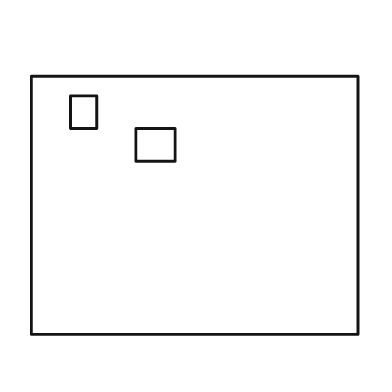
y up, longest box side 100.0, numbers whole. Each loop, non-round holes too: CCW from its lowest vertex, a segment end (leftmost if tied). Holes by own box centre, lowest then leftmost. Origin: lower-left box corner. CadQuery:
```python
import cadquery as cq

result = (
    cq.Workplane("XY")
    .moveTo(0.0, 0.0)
    .lineTo(100.0, 0.0)
    .lineTo(100.0, 79.0)
    .lineTo(0.0, 79.0)
    .close()
    .moveTo(32.0, 53.0)
    .lineTo(44.0, 53.0)
    .lineTo(44.0, 63.0)
    .lineTo(32.0, 63.0)
    .close()
    .moveTo(12.0, 63.0)
    .lineTo(20.0, 63.0)
    .lineTo(20.0, 73.0)
    .lineTo(12.0, 73.0)
    .close()
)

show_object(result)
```